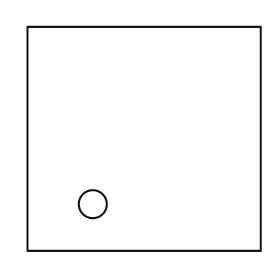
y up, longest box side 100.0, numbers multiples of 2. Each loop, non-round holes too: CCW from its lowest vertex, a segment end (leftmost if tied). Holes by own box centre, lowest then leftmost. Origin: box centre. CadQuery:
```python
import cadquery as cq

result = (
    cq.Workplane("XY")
    .moveTo(-50.0, -48.0)
    .lineTo(50.0, -48.0)
    .lineTo(50.0, 48.0)
    .lineTo(-50.0, 48.0)
    .close()
    .moveTo(-22.0, -28.0)
    .circle(6.0)
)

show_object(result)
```